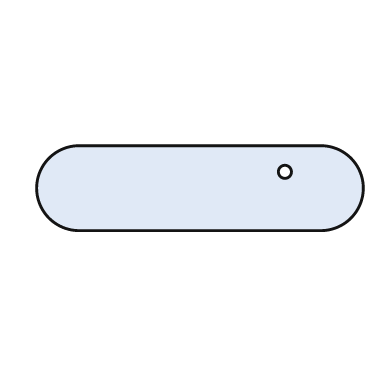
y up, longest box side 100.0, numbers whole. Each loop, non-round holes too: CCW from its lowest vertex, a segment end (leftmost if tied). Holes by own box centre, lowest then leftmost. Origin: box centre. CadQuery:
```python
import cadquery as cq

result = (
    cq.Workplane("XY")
    .moveTo(-37.0, -13.0)
    .lineTo(37.0, -13.0)
    .threePointArc((50.0, 0.0), (37.0, 13.0))
    .lineTo(-37.0, 13.0)
    .threePointArc((-50.0, 0.0), (-37.0, -13.0))
    .close()
    .moveTo(26.0, 5.0)
    .circle(2.0)
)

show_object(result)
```